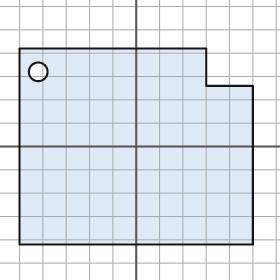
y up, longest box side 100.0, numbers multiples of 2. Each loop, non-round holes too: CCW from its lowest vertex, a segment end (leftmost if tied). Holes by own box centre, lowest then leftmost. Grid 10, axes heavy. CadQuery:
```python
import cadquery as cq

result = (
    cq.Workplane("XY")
    .moveTo(-50.0, -42.0)
    .lineTo(50.0, -42.0)
    .lineTo(50.0, 26.0)
    .lineTo(30.0, 26.0)
    .lineTo(30.0, 42.0)
    .lineTo(-50.0, 42.0)
    .close()
    .moveTo(-42.0, 32.0)
    .circle(4.0)
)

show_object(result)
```